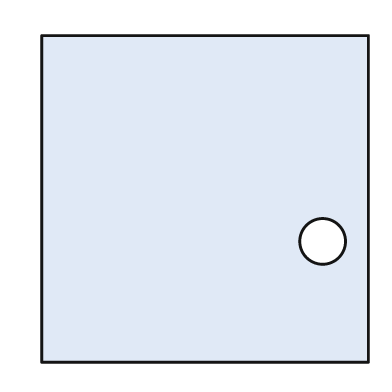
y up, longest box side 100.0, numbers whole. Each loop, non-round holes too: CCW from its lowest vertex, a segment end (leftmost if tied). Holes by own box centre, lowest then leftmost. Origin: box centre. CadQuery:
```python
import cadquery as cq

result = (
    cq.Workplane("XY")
    .moveTo(-50.0, -50.0)
    .lineTo(50.0, -50.0)
    .lineTo(50.0, 50.0)
    .lineTo(-50.0, 50.0)
    .close()
    .moveTo(36.0, -13.0)
    .circle(7.0)
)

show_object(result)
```